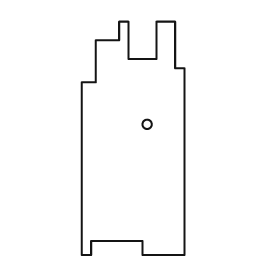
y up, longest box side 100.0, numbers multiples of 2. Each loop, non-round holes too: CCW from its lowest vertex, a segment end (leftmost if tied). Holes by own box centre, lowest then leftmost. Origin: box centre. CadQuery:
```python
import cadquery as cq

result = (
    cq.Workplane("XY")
    .moveTo(-22.0, -50.0)
    .lineTo(-18.0, -50.0)
    .lineTo(-18.0, -44.0)
    .lineTo(4.0, -44.0)
    .lineTo(4.0, -50.0)
    .lineTo(22.0, -50.0)
    .lineTo(22.0, 30.0)
    .lineTo(18.0, 30.0)
    .lineTo(18.0, 50.0)
    .lineTo(10.0, 50.0)
    .lineTo(10.0, 34.0)
    .lineTo(-2.0, 34.0)
    .lineTo(-2.0, 50.0)
    .lineTo(-6.0, 50.0)
    .lineTo(-6.0, 42.0)
    .lineTo(-16.0, 42.0)
    .lineTo(-16.0, 24.0)
    .lineTo(-22.0, 24.0)
    .close()
    .moveTo(6.0, 6.0)
    .circle(2.0)
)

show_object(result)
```